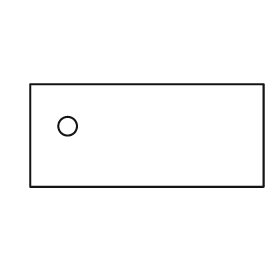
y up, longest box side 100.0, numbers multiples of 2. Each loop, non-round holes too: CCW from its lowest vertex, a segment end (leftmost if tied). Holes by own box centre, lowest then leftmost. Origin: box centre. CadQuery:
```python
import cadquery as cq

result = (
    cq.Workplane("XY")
    .moveTo(-50.0, -22.0)
    .lineTo(50.0, -22.0)
    .lineTo(50.0, 22.0)
    .lineTo(-50.0, 22.0)
    .close()
    .moveTo(-34.0, 4.0)
    .circle(4.0)
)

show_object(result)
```